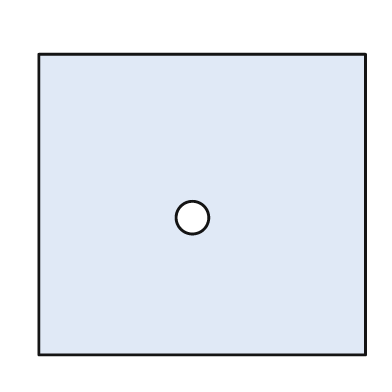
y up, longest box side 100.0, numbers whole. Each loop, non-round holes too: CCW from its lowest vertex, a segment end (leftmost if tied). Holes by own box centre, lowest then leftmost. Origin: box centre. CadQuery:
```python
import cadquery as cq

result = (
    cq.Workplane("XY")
    .moveTo(-50.0, -46.0)
    .lineTo(50.0, -46.0)
    .lineTo(50.0, 46.0)
    .lineTo(-50.0, 46.0)
    .close()
    .moveTo(-3.0, -4.0)
    .circle(5.0)
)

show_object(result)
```